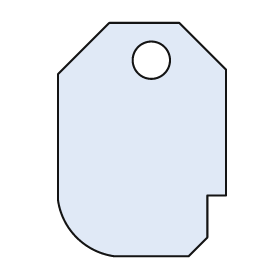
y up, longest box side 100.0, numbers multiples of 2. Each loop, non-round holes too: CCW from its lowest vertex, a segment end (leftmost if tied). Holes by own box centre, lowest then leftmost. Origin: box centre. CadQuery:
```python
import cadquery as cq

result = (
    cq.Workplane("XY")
    .moveTo(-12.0, -50.0)
    .lineTo(20.0, -50.0)
    .lineTo(28.0, -42.0)
    .lineTo(28.0, -24.0)
    .lineTo(36.0, -24.0)
    .lineTo(36.0, 30.0)
    .lineTo(16.0, 50.0)
    .lineTo(-14.0, 50.0)
    .lineTo(-36.0, 28.0)
    .lineTo(-36.0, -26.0)
    .threePointArc((-28.0, -42.0), (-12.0, -50.0))
    .close()
    .moveTo(4.0, 34.0)
    .circle(8.0)
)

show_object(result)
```